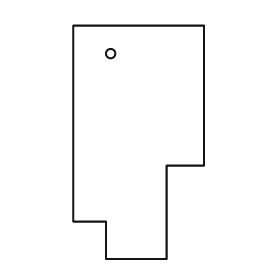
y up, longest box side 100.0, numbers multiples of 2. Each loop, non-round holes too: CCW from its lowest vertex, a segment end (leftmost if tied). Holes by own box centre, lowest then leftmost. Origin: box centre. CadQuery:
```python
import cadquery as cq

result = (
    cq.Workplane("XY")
    .moveTo(-14.0, -50.0)
    .lineTo(12.0, -50.0)
    .lineTo(12.0, -10.0)
    .lineTo(28.0, -10.0)
    .lineTo(28.0, 50.0)
    .lineTo(-28.0, 50.0)
    .lineTo(-28.0, -34.0)
    .lineTo(-14.0, -34.0)
    .close()
    .moveTo(-12.0, 38.0)
    .circle(2.0)
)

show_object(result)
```